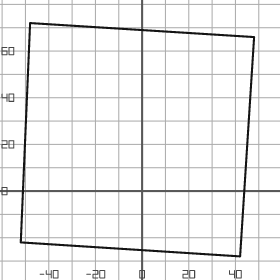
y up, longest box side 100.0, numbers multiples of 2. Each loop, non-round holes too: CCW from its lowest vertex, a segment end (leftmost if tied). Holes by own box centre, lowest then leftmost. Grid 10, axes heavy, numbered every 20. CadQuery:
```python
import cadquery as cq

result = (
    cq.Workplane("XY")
    .moveTo(42.0, -28.0)
    .lineTo(48.0, 66.0)
    .lineTo(-48.0, 72.0)
    .lineTo(-52.0, -22.0)
    .close()
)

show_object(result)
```